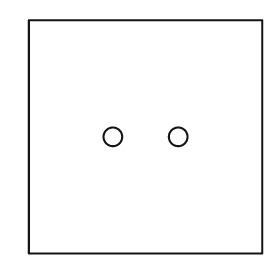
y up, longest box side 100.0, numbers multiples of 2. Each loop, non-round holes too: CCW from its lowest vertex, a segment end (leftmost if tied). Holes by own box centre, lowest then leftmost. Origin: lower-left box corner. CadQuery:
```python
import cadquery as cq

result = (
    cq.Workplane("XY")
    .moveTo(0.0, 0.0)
    .lineTo(100.0, 0.0)
    .lineTo(100.0, 100.0)
    .lineTo(0.0, 100.0)
    .close()
    .moveTo(36.0, 50.0)
    .circle(4.0)
    .moveTo(64.0, 50.0)
    .circle(4.0)
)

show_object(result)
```